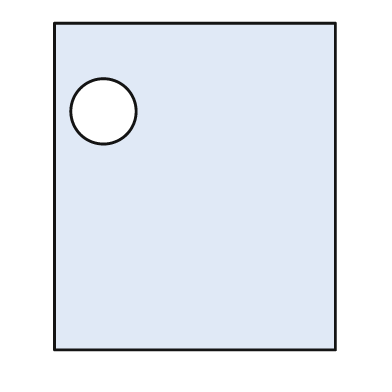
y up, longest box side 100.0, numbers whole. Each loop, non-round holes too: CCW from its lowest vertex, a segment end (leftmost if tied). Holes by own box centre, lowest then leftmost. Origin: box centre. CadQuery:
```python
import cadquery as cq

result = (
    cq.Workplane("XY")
    .moveTo(-43.0, -50.0)
    .lineTo(43.0, -50.0)
    .lineTo(43.0, 50.0)
    .lineTo(-43.0, 50.0)
    .close()
    .moveTo(-28.0, 23.0)
    .circle(10.0)
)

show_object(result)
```